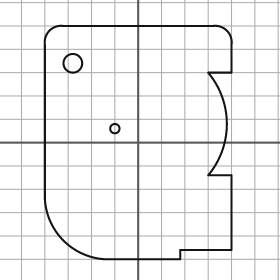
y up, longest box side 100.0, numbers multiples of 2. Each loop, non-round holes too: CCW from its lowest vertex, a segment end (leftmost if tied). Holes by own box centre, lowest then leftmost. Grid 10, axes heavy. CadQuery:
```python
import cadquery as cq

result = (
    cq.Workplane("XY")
    .moveTo(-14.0, -50.0)
    .lineTo(18.0, -50.0)
    .lineTo(18.0, -46.0)
    .lineTo(40.0, -46.0)
    .lineTo(40.0, -14.0)
    .lineTo(30.0, -14.0)
    .threePointArc((38.0, 8.0), (30.0, 30.0))
    .lineTo(40.0, 30.0)
    .lineTo(40.0, 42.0)
    .threePointArc((38.0, 48.0), (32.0, 50.0))
    .lineTo(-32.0, 50.0)
    .threePointArc((-38.0, 48.0), (-40.0, 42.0))
    .lineTo(-40.0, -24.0)
    .threePointArc((-32.0, -42.0), (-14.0, -50.0))
    .close()
    .moveTo(-10.0, 6.0)
    .circle(2.0)
    .moveTo(-28.0, 34.0)
    .circle(4.0)
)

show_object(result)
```